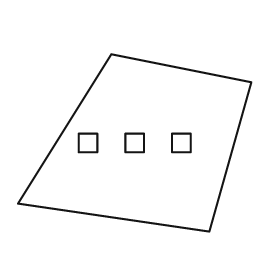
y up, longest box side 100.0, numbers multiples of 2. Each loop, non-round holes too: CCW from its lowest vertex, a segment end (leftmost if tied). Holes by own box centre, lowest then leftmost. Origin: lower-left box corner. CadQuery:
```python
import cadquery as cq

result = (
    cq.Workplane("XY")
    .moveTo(82.0, 0.0)
    .lineTo(100.0, 64.0)
    .lineTo(40.0, 76.0)
    .lineTo(0.0, 12.0)
    .close()
    .moveTo(26.0, 34.0)
    .lineTo(34.0, 34.0)
    .lineTo(34.0, 42.0)
    .lineTo(26.0, 42.0)
    .close()
    .moveTo(46.0, 34.0)
    .lineTo(54.0, 34.0)
    .lineTo(54.0, 42.0)
    .lineTo(46.0, 42.0)
    .close()
    .moveTo(66.0, 34.0)
    .lineTo(74.0, 34.0)
    .lineTo(74.0, 42.0)
    .lineTo(66.0, 42.0)
    .close()
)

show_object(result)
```